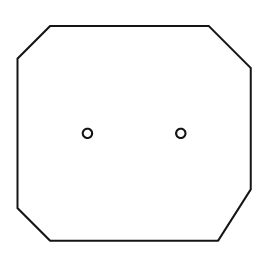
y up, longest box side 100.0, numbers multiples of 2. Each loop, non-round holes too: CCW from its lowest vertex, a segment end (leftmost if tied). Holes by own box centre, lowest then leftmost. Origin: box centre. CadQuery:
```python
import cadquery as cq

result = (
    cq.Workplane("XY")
    .moveTo(-36.0, -46.0)
    .lineTo(36.0, -46.0)
    .lineTo(50.0, -24.0)
    .lineTo(50.0, 28.0)
    .lineTo(32.0, 46.0)
    .lineTo(-36.0, 46.0)
    .lineTo(-50.0, 32.0)
    .lineTo(-50.0, -32.0)
    .close()
    .moveTo(-20.0, 0.0)
    .circle(2.0)
    .moveTo(20.0, 0.0)
    .circle(2.0)
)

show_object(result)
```